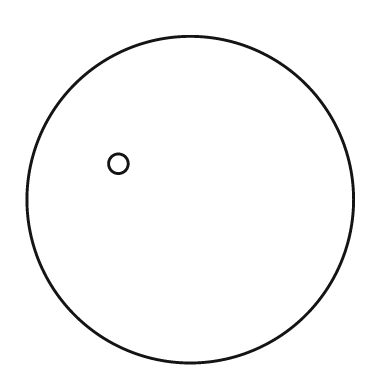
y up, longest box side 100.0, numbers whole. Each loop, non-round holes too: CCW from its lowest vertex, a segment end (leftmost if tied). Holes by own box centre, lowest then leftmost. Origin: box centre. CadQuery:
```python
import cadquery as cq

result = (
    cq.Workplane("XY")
    .moveTo(0.0, 0.0)
    .circle(50.0)
    .moveTo(-22.0, 11.0)
    .circle(3.0)
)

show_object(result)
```